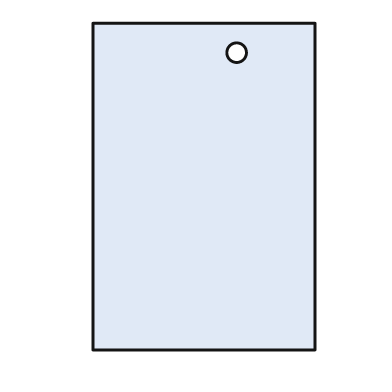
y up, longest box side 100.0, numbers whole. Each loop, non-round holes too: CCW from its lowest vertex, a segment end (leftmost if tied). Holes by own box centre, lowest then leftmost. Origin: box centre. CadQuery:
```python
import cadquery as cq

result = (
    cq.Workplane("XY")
    .moveTo(-34.0, -50.0)
    .lineTo(34.0, -50.0)
    .lineTo(34.0, 50.0)
    .lineTo(-34.0, 50.0)
    .close()
    .moveTo(10.0, 41.0)
    .circle(3.0)
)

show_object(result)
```